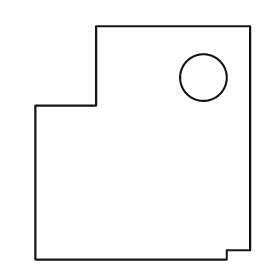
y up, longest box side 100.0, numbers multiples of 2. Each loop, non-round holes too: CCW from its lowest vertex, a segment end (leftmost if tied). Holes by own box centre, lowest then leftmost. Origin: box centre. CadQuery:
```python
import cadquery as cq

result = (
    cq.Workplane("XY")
    .moveTo(-46.0, -50.0)
    .lineTo(36.0, -50.0)
    .lineTo(36.0, -46.0)
    .lineTo(46.0, -46.0)
    .lineTo(46.0, 50.0)
    .lineTo(-20.0, 50.0)
    .lineTo(-20.0, 16.0)
    .lineTo(-46.0, 16.0)
    .close()
    .moveTo(26.0, 28.0)
    .circle(10.0)
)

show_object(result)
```